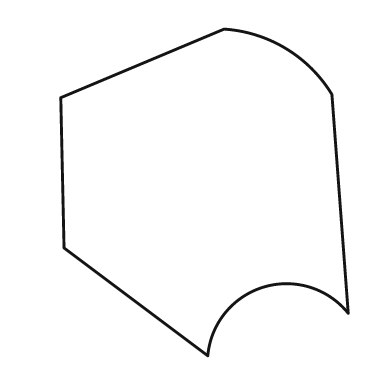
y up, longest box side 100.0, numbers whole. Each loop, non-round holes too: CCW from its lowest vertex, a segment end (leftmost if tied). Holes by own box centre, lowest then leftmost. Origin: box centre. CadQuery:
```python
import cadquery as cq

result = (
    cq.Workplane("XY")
    .moveTo(1.0, -50.0)
    .threePointArc((18.0, -29.0), (44.0, -37.0))
    .lineTo(39.0, 30.0)
    .threePointArc((25.0, 44.0), (6.0, 50.0))
    .lineTo(-44.0, 29.0)
    .lineTo(-43.0, -17.0)
    .close()
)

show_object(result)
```